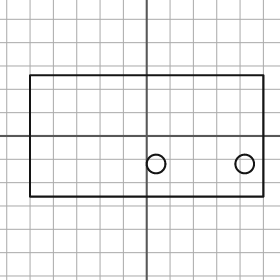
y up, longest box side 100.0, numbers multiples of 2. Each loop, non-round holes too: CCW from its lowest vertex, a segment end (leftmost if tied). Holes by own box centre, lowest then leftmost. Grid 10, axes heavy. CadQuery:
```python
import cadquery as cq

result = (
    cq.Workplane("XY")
    .moveTo(-50.0, -26.0)
    .lineTo(50.0, -26.0)
    .lineTo(50.0, 26.0)
    .lineTo(-50.0, 26.0)
    .close()
    .moveTo(4.0, -12.0)
    .circle(4.0)
    .moveTo(42.0, -12.0)
    .circle(4.0)
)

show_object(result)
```